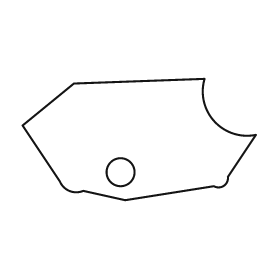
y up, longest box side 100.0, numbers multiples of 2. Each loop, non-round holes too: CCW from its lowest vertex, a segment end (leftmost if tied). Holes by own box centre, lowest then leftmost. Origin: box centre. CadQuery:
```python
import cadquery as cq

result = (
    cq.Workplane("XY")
    .moveTo(-6.0, -26.0)
    .lineTo(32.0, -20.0)
    .threePointArc((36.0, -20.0), (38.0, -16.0))
    .lineTo(50.0, 2.0)
    .threePointArc((32.0, 8.0), (28.0, 26.0))
    .lineTo(-28.0, 24.0)
    .lineTo(-50.0, 6.0)
    .lineTo(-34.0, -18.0)
    .threePointArc((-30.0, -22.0), (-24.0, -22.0))
    .close()
    .moveTo(-8.0, -14.0)
    .circle(6.0)
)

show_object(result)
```